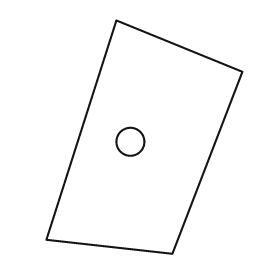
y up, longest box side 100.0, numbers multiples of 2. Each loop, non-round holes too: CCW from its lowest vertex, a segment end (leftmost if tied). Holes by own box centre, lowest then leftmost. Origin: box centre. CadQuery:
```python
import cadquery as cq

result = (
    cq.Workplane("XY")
    .moveTo(12.0, -50.0)
    .lineTo(42.0, 28.0)
    .lineTo(-12.0, 50.0)
    .lineTo(-42.0, -44.0)
    .close()
    .moveTo(-6.0, -2.0)
    .circle(6.0)
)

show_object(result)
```